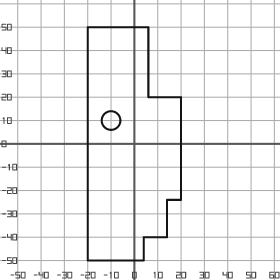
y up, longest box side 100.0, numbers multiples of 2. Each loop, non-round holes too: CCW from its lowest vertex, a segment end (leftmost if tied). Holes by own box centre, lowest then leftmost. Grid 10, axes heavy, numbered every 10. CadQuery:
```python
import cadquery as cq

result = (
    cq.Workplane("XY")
    .moveTo(-20.0, -50.0)
    .lineTo(4.0, -50.0)
    .lineTo(4.0, -40.0)
    .lineTo(14.0, -40.0)
    .lineTo(14.0, -24.0)
    .lineTo(20.0, -24.0)
    .lineTo(20.0, 20.0)
    .lineTo(6.0, 20.0)
    .lineTo(6.0, 50.0)
    .lineTo(-20.0, 50.0)
    .close()
    .moveTo(-10.0, 10.0)
    .circle(4.0)
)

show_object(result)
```